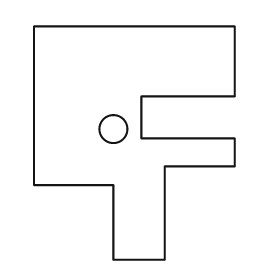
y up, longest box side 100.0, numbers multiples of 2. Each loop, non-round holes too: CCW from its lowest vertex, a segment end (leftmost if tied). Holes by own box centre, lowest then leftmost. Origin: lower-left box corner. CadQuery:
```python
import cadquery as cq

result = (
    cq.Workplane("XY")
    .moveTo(34.0, 0.0)
    .lineTo(56.0, 0.0)
    .lineTo(56.0, 40.0)
    .lineTo(86.0, 40.0)
    .lineTo(86.0, 52.0)
    .lineTo(46.0, 52.0)
    .lineTo(46.0, 70.0)
    .lineTo(86.0, 70.0)
    .lineTo(86.0, 100.0)
    .lineTo(0.0, 100.0)
    .lineTo(0.0, 32.0)
    .lineTo(34.0, 32.0)
    .close()
    .moveTo(34.0, 56.0)
    .circle(6.0)
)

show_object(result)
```